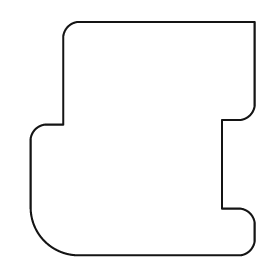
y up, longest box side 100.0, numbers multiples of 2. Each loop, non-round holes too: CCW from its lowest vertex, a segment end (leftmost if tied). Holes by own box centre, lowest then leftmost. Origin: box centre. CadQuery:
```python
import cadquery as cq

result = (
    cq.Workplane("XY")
    .moveTo(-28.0, -50.0)
    .lineTo(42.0, -50.0)
    .threePointArc((46.0, -48.0), (48.0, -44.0))
    .lineTo(48.0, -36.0)
    .threePointArc((46.0, -32.0), (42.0, -30.0))
    .lineTo(34.0, -30.0)
    .lineTo(34.0, 8.0)
    .lineTo(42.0, 8.0)
    .threePointArc((46.0, 10.0), (48.0, 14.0))
    .lineTo(48.0, 50.0)
    .lineTo(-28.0, 50.0)
    .threePointArc((-32.0, 48.0), (-34.0, 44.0))
    .lineTo(-34.0, 6.0)
    .lineTo(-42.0, 6.0)
    .threePointArc((-46.0, 4.0), (-48.0, 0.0))
    .lineTo(-48.0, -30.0)
    .threePointArc((-42.0, -44.0), (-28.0, -50.0))
    .close()
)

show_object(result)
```